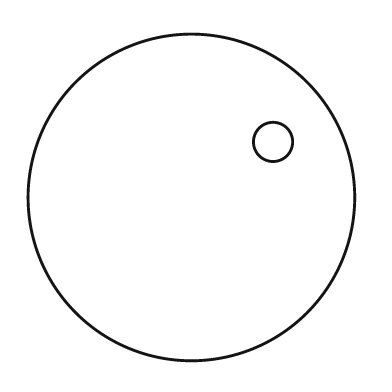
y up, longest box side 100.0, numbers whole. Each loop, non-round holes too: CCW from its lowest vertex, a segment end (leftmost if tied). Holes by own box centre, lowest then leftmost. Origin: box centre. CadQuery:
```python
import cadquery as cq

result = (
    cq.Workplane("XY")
    .moveTo(0.0, 0.0)
    .circle(50.0)
    .moveTo(25.0, 17.0)
    .circle(6.0)
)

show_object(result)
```